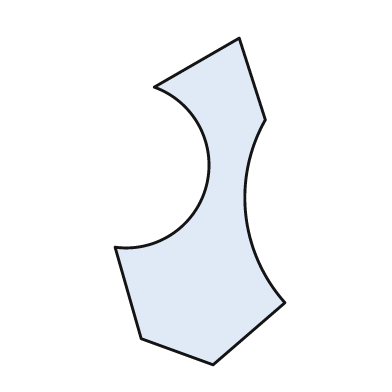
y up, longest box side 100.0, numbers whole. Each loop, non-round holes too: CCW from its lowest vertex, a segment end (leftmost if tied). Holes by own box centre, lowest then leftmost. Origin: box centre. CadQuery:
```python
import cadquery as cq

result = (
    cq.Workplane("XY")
    .moveTo(4.0, -50.0)
    .lineTo(26.0, -31.0)
    .threePointArc((14.0, -4.0), (20.0, 25.0))
    .lineTo(12.0, 50.0)
    .lineTo(-14.0, 35.0)
    .threePointArc((2.0, 5.0), (-26.0, -14.0))
    .lineTo(-18.0, -42.0)
    .close()
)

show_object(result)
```